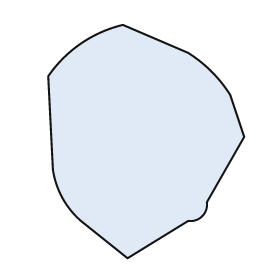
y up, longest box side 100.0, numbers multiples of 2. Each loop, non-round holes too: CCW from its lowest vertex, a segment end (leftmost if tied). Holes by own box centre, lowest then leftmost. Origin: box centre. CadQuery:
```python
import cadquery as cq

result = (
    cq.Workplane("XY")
    .moveTo(-8.0, -50.0)
    .lineTo(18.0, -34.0)
    .threePointArc((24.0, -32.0), (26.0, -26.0))
    .lineTo(42.0, 2.0)
    .lineTo(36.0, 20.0)
    .threePointArc((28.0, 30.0), (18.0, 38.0))
    .lineTo(-10.0, 50.0)
    .threePointArc((-28.0, 42.0), (-42.0, 28.0))
    .lineTo(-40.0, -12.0)
    .threePointArc((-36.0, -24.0), (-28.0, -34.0))
    .close()
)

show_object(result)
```